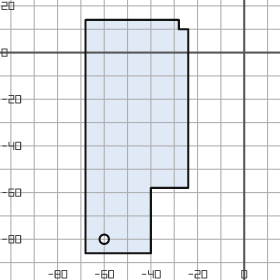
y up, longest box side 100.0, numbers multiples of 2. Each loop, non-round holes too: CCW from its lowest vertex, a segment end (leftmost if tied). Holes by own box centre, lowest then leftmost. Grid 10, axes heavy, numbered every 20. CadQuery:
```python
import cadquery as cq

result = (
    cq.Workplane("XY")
    .moveTo(-68.0, -86.0)
    .lineTo(-40.0, -86.0)
    .lineTo(-40.0, -58.0)
    .lineTo(-24.0, -58.0)
    .lineTo(-24.0, 10.0)
    .lineTo(-28.0, 10.0)
    .lineTo(-28.0, 14.0)
    .lineTo(-68.0, 14.0)
    .close()
    .moveTo(-60.0, -80.0)
    .circle(2.0)
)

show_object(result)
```